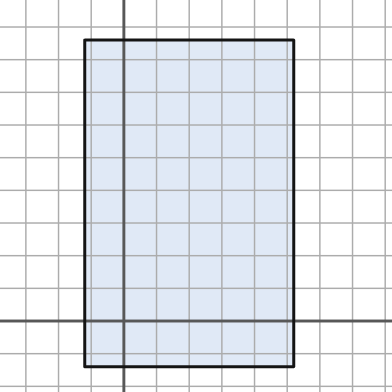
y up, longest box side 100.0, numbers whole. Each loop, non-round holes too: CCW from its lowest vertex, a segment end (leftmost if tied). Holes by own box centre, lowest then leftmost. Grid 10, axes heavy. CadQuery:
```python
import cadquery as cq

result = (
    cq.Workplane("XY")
    .moveTo(-12.0, -14.0)
    .lineTo(52.0, -14.0)
    .lineTo(52.0, 86.0)
    .lineTo(-12.0, 86.0)
    .close()
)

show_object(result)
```